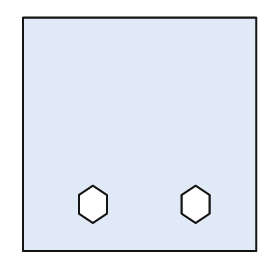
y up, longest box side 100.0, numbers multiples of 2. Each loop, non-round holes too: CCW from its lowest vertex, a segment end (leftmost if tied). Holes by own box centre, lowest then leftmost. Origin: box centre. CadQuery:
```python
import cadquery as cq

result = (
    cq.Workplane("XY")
    .moveTo(-50.0, -50.0)
    .lineTo(50.0, -50.0)
    .lineTo(50.0, 50.0)
    .lineTo(-50.0, 50.0)
    .close()
    .moveTo(-20.0, -38.0)
    .lineTo(-14.0, -34.0)
    .lineTo(-14.0, -26.0)
    .lineTo(-20.0, -22.0)
    .lineTo(-26.0, -26.0)
    .lineTo(-26.0, -34.0)
    .close()
    .moveTo(24.0, -38.0)
    .lineTo(30.0, -34.0)
    .lineTo(30.0, -26.0)
    .lineTo(24.0, -22.0)
    .lineTo(18.0, -26.0)
    .lineTo(18.0, -34.0)
    .close()
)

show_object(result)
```